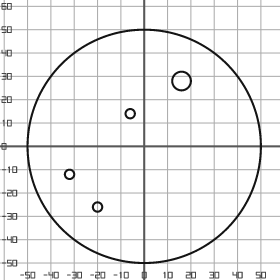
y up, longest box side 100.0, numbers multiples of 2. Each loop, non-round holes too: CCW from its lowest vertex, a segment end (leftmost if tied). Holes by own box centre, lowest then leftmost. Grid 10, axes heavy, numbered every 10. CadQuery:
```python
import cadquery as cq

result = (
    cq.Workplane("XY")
    .moveTo(0.0, 0.0)
    .circle(50.0)
    .moveTo(-20.0, -26.0)
    .circle(2.0)
    .moveTo(-32.0, -12.0)
    .circle(2.0)
    .moveTo(-6.0, 14.0)
    .circle(2.0)
    .moveTo(16.0, 28.0)
    .circle(4.0)
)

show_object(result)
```